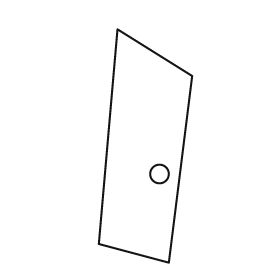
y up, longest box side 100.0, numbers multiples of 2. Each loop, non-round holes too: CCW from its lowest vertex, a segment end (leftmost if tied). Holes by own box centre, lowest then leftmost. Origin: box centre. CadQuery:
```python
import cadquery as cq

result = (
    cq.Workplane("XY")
    .moveTo(10.0, -50.0)
    .lineTo(20.0, 30.0)
    .lineTo(-12.0, 50.0)
    .lineTo(-20.0, -42.0)
    .close()
    .moveTo(6.0, -12.0)
    .circle(4.0)
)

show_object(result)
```